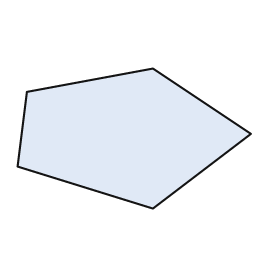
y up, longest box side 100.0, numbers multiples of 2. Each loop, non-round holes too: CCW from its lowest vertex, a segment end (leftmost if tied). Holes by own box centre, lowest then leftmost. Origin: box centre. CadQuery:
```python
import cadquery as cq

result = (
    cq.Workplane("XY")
    .moveTo(8.0, -30.0)
    .lineTo(50.0, 2.0)
    .lineTo(8.0, 30.0)
    .lineTo(-46.0, 20.0)
    .lineTo(-50.0, -12.0)
    .close()
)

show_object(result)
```